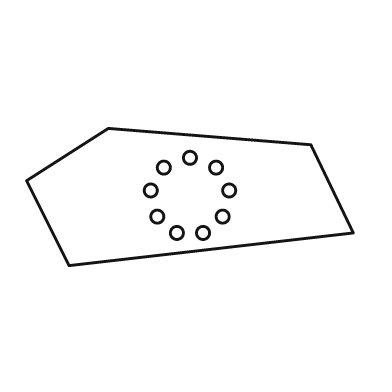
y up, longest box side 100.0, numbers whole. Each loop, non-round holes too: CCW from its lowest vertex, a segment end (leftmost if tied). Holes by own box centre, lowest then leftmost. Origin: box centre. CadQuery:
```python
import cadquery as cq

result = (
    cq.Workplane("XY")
    .moveTo(-37.0, -21.0)
    .lineTo(50.0, -11.0)
    .lineTo(37.0, 16.0)
    .lineTo(-25.0, 21.0)
    .lineTo(-50.0, 5.0)
    .close()
    .moveTo(-4.0, -11.0)
    .circle(2.0)
    .moveTo(4.0, -11.0)
    .circle(2.0)
    .moveTo(-10.0, -6.0)
    .circle(2.0)
    .moveTo(10.0, -6.0)
    .circle(2.0)
    .moveTo(-12.0, 2.0)
    .circle(2.0)
    .moveTo(12.0, 2.0)
    .circle(2.0)
    .moveTo(-8.0, 9.0)
    .circle(2.0)
    .moveTo(8.0, 9.0)
    .circle(2.0)
    .moveTo(0.0, 12.0)
    .circle(2.0)
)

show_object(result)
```